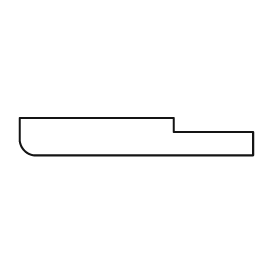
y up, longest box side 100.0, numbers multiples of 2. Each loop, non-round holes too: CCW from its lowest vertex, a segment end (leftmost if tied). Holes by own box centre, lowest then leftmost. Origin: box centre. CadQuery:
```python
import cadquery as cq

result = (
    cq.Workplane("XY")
    .moveTo(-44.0, -8.0)
    .lineTo(50.0, -8.0)
    .lineTo(50.0, 2.0)
    .lineTo(16.0, 2.0)
    .lineTo(16.0, 8.0)
    .lineTo(-50.0, 8.0)
    .lineTo(-50.0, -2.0)
    .threePointArc((-48.0, -6.0), (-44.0, -8.0))
    .close()
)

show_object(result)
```